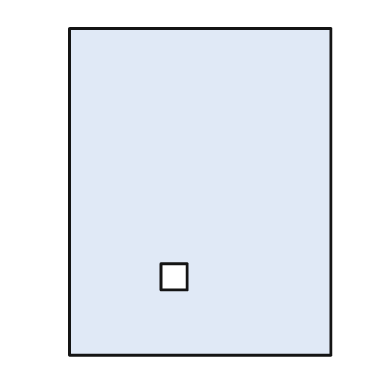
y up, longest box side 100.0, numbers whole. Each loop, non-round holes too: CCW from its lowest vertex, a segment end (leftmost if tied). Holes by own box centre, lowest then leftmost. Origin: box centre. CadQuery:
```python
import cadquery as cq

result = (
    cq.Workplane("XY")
    .moveTo(-40.0, -50.0)
    .lineTo(40.0, -50.0)
    .lineTo(40.0, 50.0)
    .lineTo(-40.0, 50.0)
    .close()
    .moveTo(-12.0, -30.0)
    .lineTo(-4.0, -30.0)
    .lineTo(-4.0, -22.0)
    .lineTo(-12.0, -22.0)
    .close()
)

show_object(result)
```